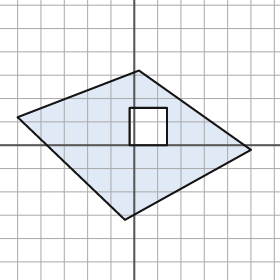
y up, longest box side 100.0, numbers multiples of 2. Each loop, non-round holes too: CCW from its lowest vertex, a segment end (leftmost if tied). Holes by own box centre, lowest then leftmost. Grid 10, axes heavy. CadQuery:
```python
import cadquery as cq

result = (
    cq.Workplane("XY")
    .moveTo(-4.0, -32.0)
    .lineTo(50.0, -2.0)
    .lineTo(2.0, 32.0)
    .lineTo(-50.0, 12.0)
    .close()
    .moveTo(-2.0, 0.0)
    .lineTo(14.0, 0.0)
    .lineTo(14.0, 16.0)
    .lineTo(-2.0, 16.0)
    .close()
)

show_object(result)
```